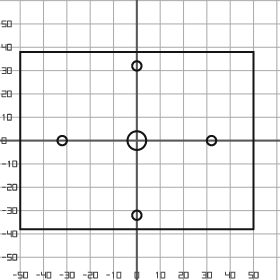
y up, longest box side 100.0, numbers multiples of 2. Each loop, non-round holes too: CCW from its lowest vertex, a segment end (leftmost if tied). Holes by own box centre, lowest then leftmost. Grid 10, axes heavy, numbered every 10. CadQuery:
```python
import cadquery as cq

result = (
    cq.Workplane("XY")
    .moveTo(-50.0, -38.0)
    .lineTo(50.0, -38.0)
    .lineTo(50.0, 38.0)
    .lineTo(-50.0, 38.0)
    .close()
    .moveTo(0.0, -32.0)
    .circle(2.0)
    .moveTo(-32.0, 0.0)
    .circle(2.0)
    .moveTo(0.0, 0.0)
    .circle(4.0)
    .moveTo(32.0, 0.0)
    .circle(2.0)
    .moveTo(0.0, 32.0)
    .circle(2.0)
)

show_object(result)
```